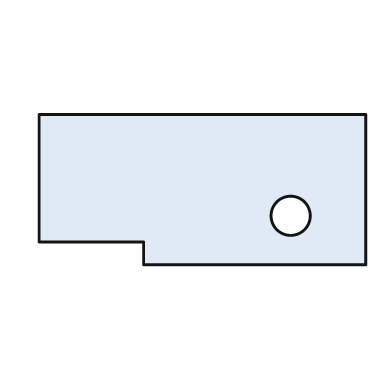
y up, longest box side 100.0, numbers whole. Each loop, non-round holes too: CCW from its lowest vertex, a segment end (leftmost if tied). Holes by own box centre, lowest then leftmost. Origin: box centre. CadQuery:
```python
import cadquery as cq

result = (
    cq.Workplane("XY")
    .moveTo(-18.0, -23.0)
    .lineTo(50.0, -23.0)
    .lineTo(50.0, 23.0)
    .lineTo(-50.0, 23.0)
    .lineTo(-50.0, -16.0)
    .lineTo(-18.0, -16.0)
    .close()
    .moveTo(27.0, -8.0)
    .circle(6.0)
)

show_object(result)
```